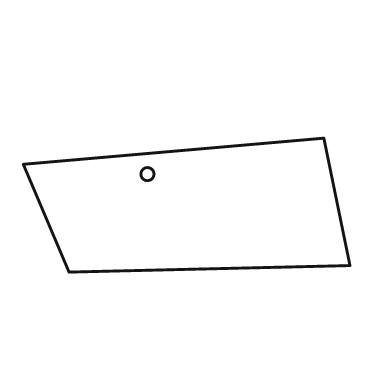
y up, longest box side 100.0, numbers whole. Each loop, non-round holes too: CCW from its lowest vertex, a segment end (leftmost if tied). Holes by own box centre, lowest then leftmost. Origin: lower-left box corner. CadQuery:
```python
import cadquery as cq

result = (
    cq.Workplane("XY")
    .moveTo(14.0, 0.0)
    .lineTo(100.0, 2.0)
    .lineTo(92.0, 41.0)
    .lineTo(0.0, 33.0)
    .close()
    .moveTo(38.0, 30.0)
    .circle(2.0)
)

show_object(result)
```